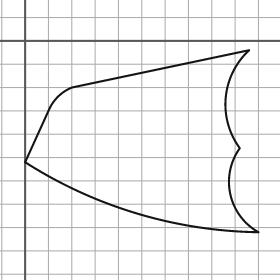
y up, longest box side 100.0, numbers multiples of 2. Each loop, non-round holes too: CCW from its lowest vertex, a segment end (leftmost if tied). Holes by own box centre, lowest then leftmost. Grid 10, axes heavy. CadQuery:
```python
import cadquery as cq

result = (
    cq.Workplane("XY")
    .moveTo(100.0, -82.0)
    .threePointArc((88.0, -66.0), (92.0, -46.0))
    .threePointArc((86.0, -24.0), (96.0, -4.0))
    .lineTo(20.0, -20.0)
    .threePointArc((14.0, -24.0), (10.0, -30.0))
    .lineTo(0.0, -52.0)
    .threePointArc((48.0, -74.0), (100.0, -82.0))
    .close()
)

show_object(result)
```